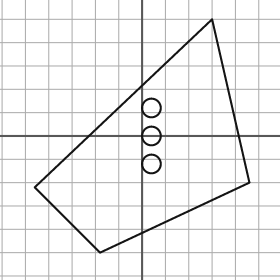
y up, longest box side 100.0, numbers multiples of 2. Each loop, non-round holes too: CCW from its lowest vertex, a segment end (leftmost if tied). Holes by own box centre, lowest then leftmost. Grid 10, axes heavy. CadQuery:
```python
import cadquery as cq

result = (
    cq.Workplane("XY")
    .moveTo(-18.0, -50.0)
    .lineTo(46.0, -20.0)
    .lineTo(30.0, 50.0)
    .lineTo(-46.0, -22.0)
    .close()
    .moveTo(4.0, -12.0)
    .circle(4.0)
    .moveTo(4.0, 0.0)
    .circle(4.0)
    .moveTo(4.0, 12.0)
    .circle(4.0)
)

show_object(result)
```